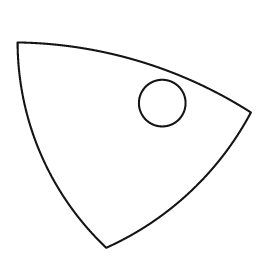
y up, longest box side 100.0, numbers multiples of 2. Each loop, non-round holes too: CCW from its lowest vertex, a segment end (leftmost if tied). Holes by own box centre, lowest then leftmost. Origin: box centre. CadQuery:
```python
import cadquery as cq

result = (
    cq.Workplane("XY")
    .moveTo(-12.0, -44.0)
    .threePointArc((24.0, -20.0), (50.0, 14.0))
    .threePointArc((2.0, 36.0), (-50.0, 44.0))
    .threePointArc((-40.0, -4.0), (-12.0, -44.0))
    .close()
    .moveTo(12.0, 18.0)
    .circle(10.0)
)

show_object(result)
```